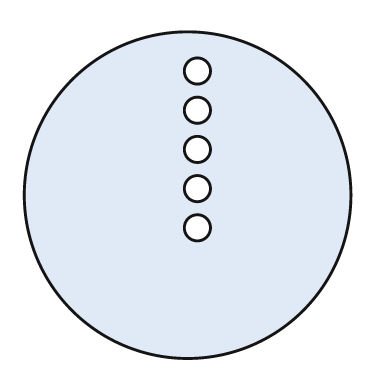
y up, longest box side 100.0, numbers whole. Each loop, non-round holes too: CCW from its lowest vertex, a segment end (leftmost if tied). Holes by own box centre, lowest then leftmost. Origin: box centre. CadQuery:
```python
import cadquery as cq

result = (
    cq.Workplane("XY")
    .moveTo(0.0, 0.0)
    .circle(50.0)
    .moveTo(3.0, -10.0)
    .circle(4.0)
    .moveTo(3.0, 2.0)
    .circle(4.0)
    .moveTo(3.0, 14.0)
    .circle(4.0)
    .moveTo(3.0, 26.0)
    .circle(4.0)
    .moveTo(3.0, 38.0)
    .circle(4.0)
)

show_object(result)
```